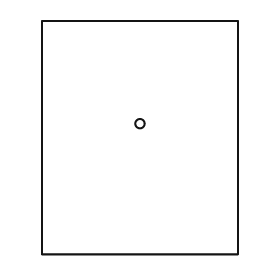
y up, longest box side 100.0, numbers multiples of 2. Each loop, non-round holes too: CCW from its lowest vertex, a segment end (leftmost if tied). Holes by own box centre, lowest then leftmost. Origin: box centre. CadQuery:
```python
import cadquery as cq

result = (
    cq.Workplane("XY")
    .moveTo(-42.0, -50.0)
    .lineTo(42.0, -50.0)
    .lineTo(42.0, 50.0)
    .lineTo(-42.0, 50.0)
    .close()
    .moveTo(0.0, 6.0)
    .circle(2.0)
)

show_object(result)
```